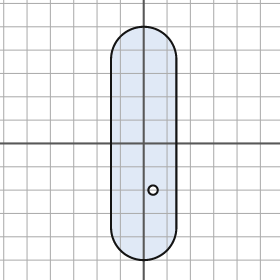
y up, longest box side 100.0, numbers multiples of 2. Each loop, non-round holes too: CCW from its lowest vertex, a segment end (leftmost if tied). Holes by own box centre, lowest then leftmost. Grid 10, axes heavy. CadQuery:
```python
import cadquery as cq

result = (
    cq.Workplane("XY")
    .moveTo(-14.0, -36.0)
    .threePointArc((0.0, -50.0), (14.0, -36.0))
    .lineTo(14.0, 36.0)
    .threePointArc((0.0, 50.0), (-14.0, 36.0))
    .close()
    .moveTo(4.0, -20.0)
    .circle(2.0)
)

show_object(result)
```